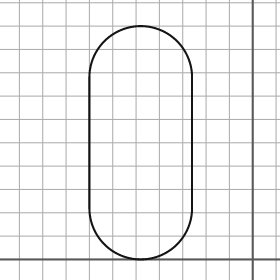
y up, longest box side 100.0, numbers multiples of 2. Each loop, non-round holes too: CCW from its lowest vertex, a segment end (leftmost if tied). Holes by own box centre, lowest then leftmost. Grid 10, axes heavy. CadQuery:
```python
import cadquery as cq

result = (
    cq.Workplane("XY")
    .moveTo(-70.0, 22.0)
    .threePointArc((-48.0, 0.0), (-26.0, 22.0))
    .lineTo(-26.0, 78.0)
    .threePointArc((-48.0, 100.0), (-70.0, 78.0))
    .close()
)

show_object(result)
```